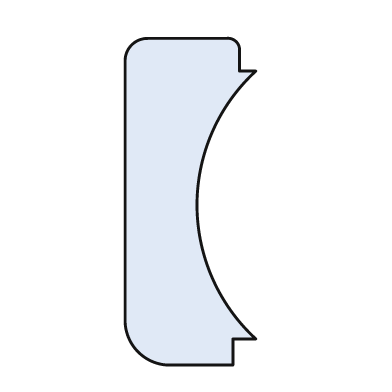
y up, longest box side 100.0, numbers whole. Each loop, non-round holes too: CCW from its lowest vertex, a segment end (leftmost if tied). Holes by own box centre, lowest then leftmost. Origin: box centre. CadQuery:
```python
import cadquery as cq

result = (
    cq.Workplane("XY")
    .moveTo(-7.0, -50.0)
    .lineTo(13.0, -50.0)
    .lineTo(13.0, -42.0)
    .lineTo(20.0, -42.0)
    .threePointArc((2.0, -1.0), (20.0, 40.0))
    .lineTo(15.0, 40.0)
    .lineTo(15.0, 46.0)
    .threePointArc((14.0, 49.0), (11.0, 50.0))
    .lineTo(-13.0, 50.0)
    .threePointArc((-18.0, 48.0), (-20.0, 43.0))
    .lineTo(-20.0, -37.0)
    .threePointArc((-16.0, -46.0), (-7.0, -50.0))
    .close()
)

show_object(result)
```